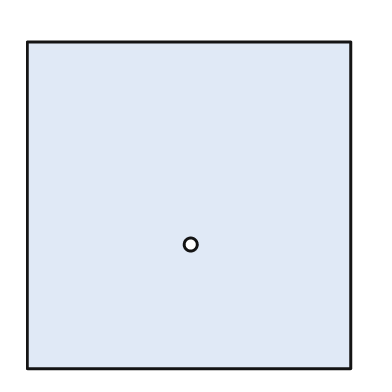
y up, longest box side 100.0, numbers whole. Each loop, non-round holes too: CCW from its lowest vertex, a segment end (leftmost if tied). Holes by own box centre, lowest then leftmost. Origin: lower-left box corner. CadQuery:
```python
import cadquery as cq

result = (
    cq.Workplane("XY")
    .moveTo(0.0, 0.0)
    .lineTo(99.0, 0.0)
    .lineTo(99.0, 100.0)
    .lineTo(0.0, 100.0)
    .close()
    .moveTo(50.0, 38.0)
    .circle(2.0)
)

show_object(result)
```